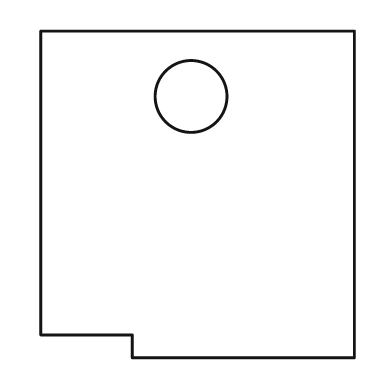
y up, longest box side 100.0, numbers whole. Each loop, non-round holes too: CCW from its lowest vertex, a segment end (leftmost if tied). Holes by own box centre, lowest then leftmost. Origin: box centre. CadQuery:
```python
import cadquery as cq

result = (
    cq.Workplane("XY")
    .moveTo(-20.0, -50.0)
    .lineTo(48.0, -50.0)
    .lineTo(48.0, 50.0)
    .lineTo(-48.0, 50.0)
    .lineTo(-48.0, -43.0)
    .lineTo(-20.0, -43.0)
    .close()
    .moveTo(-2.0, 30.0)
    .circle(11.0)
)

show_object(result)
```